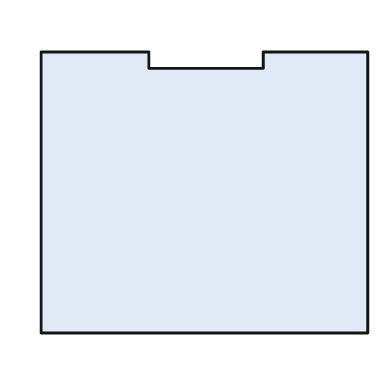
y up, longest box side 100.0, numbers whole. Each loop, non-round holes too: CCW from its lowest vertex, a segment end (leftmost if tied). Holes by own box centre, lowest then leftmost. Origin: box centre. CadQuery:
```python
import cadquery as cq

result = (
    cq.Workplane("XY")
    .moveTo(-50.0, -43.0)
    .lineTo(50.0, -43.0)
    .lineTo(50.0, 43.0)
    .lineTo(18.0, 43.0)
    .lineTo(18.0, 38.0)
    .lineTo(-17.0, 38.0)
    .lineTo(-17.0, 43.0)
    .lineTo(-50.0, 43.0)
    .close()
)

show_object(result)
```